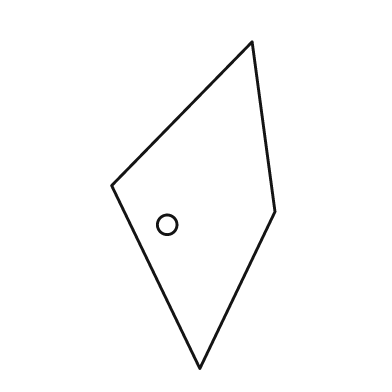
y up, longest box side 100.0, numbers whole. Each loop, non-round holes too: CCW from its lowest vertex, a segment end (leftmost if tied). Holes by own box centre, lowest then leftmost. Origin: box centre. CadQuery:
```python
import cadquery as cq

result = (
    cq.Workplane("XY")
    .moveTo(2.0, -50.0)
    .lineTo(25.0, -2.0)
    .lineTo(18.0, 50.0)
    .lineTo(-25.0, 6.0)
    .close()
    .moveTo(-8.0, -6.0)
    .circle(3.0)
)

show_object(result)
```